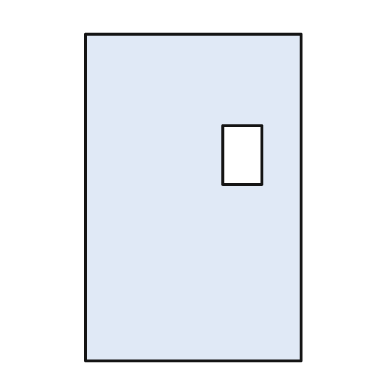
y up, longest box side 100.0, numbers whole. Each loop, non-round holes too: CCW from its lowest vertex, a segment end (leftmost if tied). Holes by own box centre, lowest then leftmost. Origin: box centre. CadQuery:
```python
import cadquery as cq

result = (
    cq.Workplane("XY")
    .moveTo(-33.0, -50.0)
    .lineTo(33.0, -50.0)
    .lineTo(33.0, 50.0)
    .lineTo(-33.0, 50.0)
    .close()
    .moveTo(9.0, 4.0)
    .lineTo(21.0, 4.0)
    .lineTo(21.0, 22.0)
    .lineTo(9.0, 22.0)
    .close()
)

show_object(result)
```